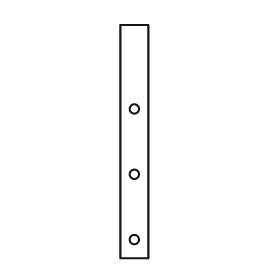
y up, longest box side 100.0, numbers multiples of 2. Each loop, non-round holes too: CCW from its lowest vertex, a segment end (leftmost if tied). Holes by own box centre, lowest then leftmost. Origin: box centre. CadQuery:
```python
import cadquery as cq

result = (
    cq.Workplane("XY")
    .moveTo(-6.0, -50.0)
    .lineTo(6.0, -50.0)
    .lineTo(6.0, 50.0)
    .lineTo(-6.0, 50.0)
    .close()
    .moveTo(0.0, -42.0)
    .circle(2.0)
    .moveTo(0.0, -14.0)
    .circle(2.0)
    .moveTo(0.0, 14.0)
    .circle(2.0)
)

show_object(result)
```